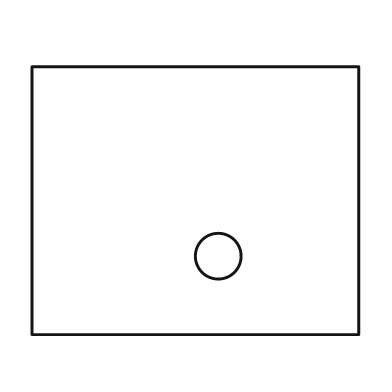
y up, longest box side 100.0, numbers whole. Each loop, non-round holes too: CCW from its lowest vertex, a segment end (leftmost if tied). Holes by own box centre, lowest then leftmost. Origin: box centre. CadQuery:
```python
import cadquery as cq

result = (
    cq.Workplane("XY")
    .moveTo(-50.0, -41.0)
    .lineTo(50.0, -41.0)
    .lineTo(50.0, 41.0)
    .lineTo(-50.0, 41.0)
    .close()
    .moveTo(7.0, -17.0)
    .circle(7.0)
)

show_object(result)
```